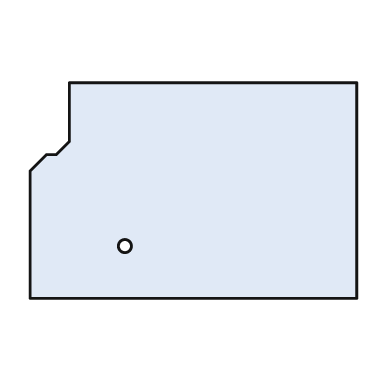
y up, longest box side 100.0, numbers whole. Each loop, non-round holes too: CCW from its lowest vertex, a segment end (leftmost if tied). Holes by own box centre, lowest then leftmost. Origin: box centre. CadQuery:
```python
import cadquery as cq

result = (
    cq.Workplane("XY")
    .moveTo(-50.0, -33.0)
    .lineTo(50.0, -33.0)
    .lineTo(50.0, 33.0)
    .lineTo(-38.0, 33.0)
    .lineTo(-38.0, 15.0)
    .lineTo(-42.0, 11.0)
    .lineTo(-45.0, 11.0)
    .lineTo(-50.0, 6.0)
    .close()
    .moveTo(-21.0, -17.0)
    .circle(2.0)
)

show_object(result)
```